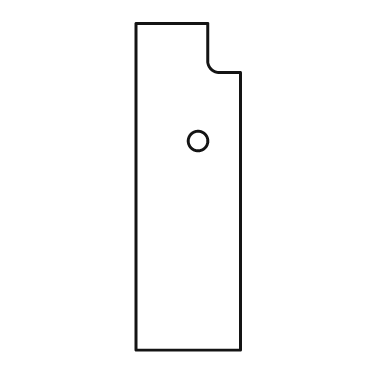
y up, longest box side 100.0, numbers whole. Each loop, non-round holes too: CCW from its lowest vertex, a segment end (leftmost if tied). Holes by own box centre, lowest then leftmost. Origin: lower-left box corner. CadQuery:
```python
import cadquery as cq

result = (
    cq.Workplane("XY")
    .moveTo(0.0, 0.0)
    .lineTo(32.0, 0.0)
    .lineTo(32.0, 85.0)
    .lineTo(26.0, 85.0)
    .threePointArc((23.0, 86.0), (22.0, 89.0))
    .lineTo(22.0, 100.0)
    .lineTo(0.0, 100.0)
    .close()
    .moveTo(19.0, 64.0)
    .circle(3.0)
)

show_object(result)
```